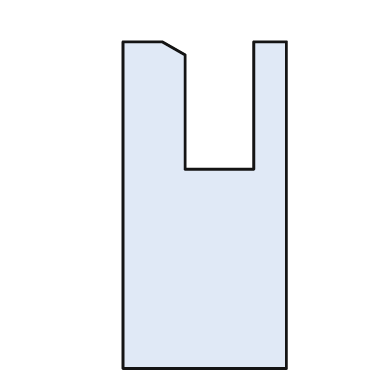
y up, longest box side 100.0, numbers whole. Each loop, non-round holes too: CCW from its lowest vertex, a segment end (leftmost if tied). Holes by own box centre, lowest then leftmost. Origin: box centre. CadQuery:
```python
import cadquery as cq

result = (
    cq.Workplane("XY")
    .moveTo(-25.0, -50.0)
    .lineTo(25.0, -50.0)
    .lineTo(25.0, 50.0)
    .lineTo(15.0, 50.0)
    .lineTo(15.0, 11.0)
    .lineTo(-6.0, 11.0)
    .lineTo(-6.0, 46.0)
    .lineTo(-13.0, 50.0)
    .lineTo(-25.0, 50.0)
    .close()
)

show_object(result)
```